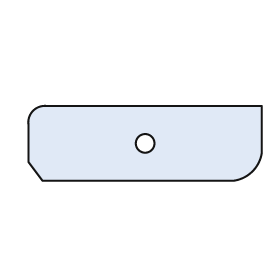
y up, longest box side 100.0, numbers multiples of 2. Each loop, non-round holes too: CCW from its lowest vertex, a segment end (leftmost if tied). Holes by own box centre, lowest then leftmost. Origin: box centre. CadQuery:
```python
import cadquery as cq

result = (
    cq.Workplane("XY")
    .moveTo(-44.0, -16.0)
    .lineTo(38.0, -16.0)
    .threePointArc((46.0, -12.0), (50.0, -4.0))
    .lineTo(50.0, 16.0)
    .lineTo(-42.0, 16.0)
    .threePointArc((-48.0, 14.0), (-50.0, 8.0))
    .lineTo(-50.0, -8.0)
    .close()
    .moveTo(0.0, 0.0)
    .circle(4.0)
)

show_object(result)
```